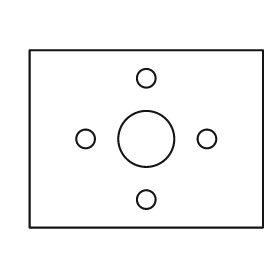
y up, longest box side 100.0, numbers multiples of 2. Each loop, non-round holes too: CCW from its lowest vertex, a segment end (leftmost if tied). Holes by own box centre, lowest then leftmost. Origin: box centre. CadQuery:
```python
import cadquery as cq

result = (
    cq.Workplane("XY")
    .moveTo(-50.0, -38.0)
    .lineTo(50.0, -38.0)
    .lineTo(50.0, 38.0)
    .lineTo(-50.0, 38.0)
    .close()
    .moveTo(0.0, -26.0)
    .circle(4.0)
    .moveTo(-26.0, 0.0)
    .circle(4.0)
    .moveTo(0.0, 0.0)
    .circle(12.0)
    .moveTo(26.0, 0.0)
    .circle(4.0)
    .moveTo(0.0, 26.0)
    .circle(4.0)
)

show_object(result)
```